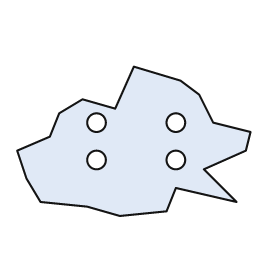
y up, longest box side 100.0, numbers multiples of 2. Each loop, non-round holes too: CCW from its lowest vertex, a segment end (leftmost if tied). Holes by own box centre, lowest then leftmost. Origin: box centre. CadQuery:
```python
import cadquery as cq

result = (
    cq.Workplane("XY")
    .moveTo(-6.0, -32.0)
    .lineTo(14.0, -30.0)
    .lineTo(18.0, -20.0)
    .lineTo(44.0, -26.0)
    .lineTo(30.0, -12.0)
    .lineTo(48.0, -4.0)
    .lineTo(50.0, 4.0)
    .lineTo(34.0, 8.0)
    .lineTo(28.0, 20.0)
    .lineTo(20.0, 26.0)
    .lineTo(0.0, 32.0)
    .lineTo(-8.0, 14.0)
    .lineTo(-22.0, 18.0)
    .lineTo(-32.0, 12.0)
    .lineTo(-36.0, 2.0)
    .lineTo(-50.0, -4.0)
    .lineTo(-46.0, -16.0)
    .lineTo(-40.0, -26.0)
    .lineTo(-20.0, -28.0)
    .close()
    .moveTo(-16.0, -8.0)
    .circle(4.0)
    .moveTo(18.0, -8.0)
    .circle(4.0)
    .moveTo(-16.0, 8.0)
    .circle(4.0)
    .moveTo(18.0, 8.0)
    .circle(4.0)
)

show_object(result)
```